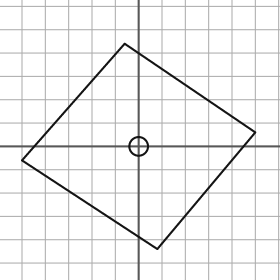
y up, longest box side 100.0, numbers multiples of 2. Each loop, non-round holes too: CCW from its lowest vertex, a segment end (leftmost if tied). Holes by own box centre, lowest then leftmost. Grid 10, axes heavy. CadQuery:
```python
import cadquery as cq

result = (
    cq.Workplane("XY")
    .moveTo(8.0, -44.0)
    .lineTo(50.0, 6.0)
    .lineTo(-6.0, 44.0)
    .lineTo(-50.0, -6.0)
    .close()
    .moveTo(0.0, 0.0)
    .circle(4.0)
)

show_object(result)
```